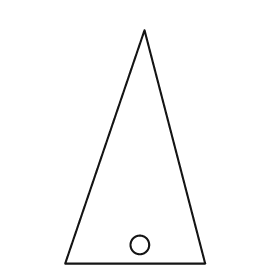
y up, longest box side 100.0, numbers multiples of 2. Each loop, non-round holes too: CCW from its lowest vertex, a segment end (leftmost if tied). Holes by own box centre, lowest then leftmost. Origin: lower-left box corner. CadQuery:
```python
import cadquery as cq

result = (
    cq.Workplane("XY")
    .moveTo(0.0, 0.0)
    .lineTo(60.0, 0.0)
    .lineTo(34.0, 100.0)
    .close()
    .moveTo(32.0, 8.0)
    .circle(4.0)
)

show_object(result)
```